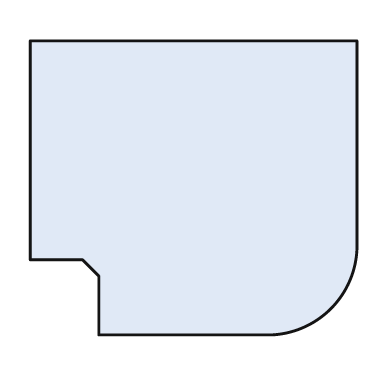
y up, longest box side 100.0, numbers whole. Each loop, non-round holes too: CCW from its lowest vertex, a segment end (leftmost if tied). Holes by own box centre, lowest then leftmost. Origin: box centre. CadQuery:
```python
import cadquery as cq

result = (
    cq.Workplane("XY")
    .moveTo(-29.0, -45.0)
    .lineTo(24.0, -45.0)
    .threePointArc((42.0, -37.0), (50.0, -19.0))
    .lineTo(50.0, 45.0)
    .lineTo(-50.0, 45.0)
    .lineTo(-50.0, -22.0)
    .lineTo(-34.0, -22.0)
    .lineTo(-29.0, -27.0)
    .close()
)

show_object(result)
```